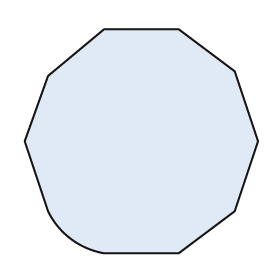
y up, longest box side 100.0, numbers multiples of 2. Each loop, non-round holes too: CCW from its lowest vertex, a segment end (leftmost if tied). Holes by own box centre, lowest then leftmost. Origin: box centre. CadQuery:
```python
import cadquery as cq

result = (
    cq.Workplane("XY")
    .moveTo(-16.0, -48.0)
    .lineTo(16.0, -48.0)
    .lineTo(40.0, -30.0)
    .lineTo(50.0, 0.0)
    .lineTo(40.0, 30.0)
    .lineTo(16.0, 48.0)
    .lineTo(-16.0, 48.0)
    .lineTo(-40.0, 28.0)
    .lineTo(-50.0, 0.0)
    .lineTo(-40.0, -30.0)
    .threePointArc((-30.0, -42.0), (-16.0, -48.0))
    .close()
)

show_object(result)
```